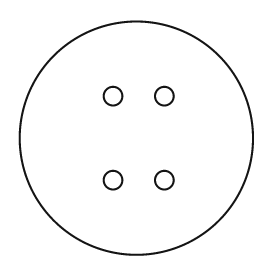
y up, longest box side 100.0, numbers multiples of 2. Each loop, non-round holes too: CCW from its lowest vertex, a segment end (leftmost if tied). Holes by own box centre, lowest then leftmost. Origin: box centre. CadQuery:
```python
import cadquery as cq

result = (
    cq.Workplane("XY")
    .moveTo(0.0, 0.0)
    .circle(50.0)
    .moveTo(-10.0, -18.0)
    .circle(4.0)
    .moveTo(12.0, -18.0)
    .circle(4.0)
    .moveTo(-10.0, 18.0)
    .circle(4.0)
    .moveTo(12.0, 18.0)
    .circle(4.0)
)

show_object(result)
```